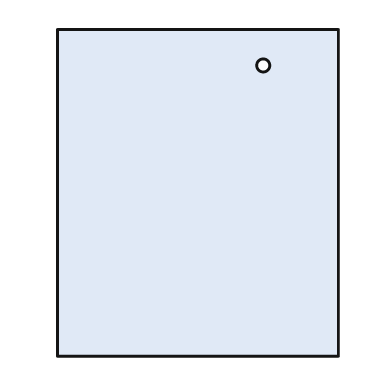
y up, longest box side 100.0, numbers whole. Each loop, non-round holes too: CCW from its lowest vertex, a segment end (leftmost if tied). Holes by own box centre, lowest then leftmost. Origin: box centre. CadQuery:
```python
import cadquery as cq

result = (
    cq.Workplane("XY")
    .moveTo(-43.0, -50.0)
    .lineTo(43.0, -50.0)
    .lineTo(43.0, 50.0)
    .lineTo(-43.0, 50.0)
    .close()
    .moveTo(20.0, 39.0)
    .circle(2.0)
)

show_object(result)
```